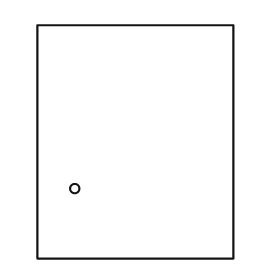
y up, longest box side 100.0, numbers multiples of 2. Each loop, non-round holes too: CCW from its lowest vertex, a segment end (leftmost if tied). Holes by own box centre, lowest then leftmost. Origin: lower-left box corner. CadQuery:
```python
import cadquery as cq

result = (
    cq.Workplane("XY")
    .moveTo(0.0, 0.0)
    .lineTo(84.0, 0.0)
    .lineTo(84.0, 100.0)
    .lineTo(0.0, 100.0)
    .close()
    .moveTo(16.0, 30.0)
    .circle(2.0)
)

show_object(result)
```